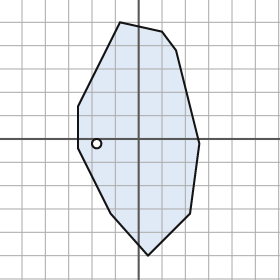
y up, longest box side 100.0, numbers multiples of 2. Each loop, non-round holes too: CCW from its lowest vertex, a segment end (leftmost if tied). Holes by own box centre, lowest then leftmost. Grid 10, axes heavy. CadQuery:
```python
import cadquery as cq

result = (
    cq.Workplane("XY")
    .moveTo(4.0, -50.0)
    .lineTo(22.0, -32.0)
    .lineTo(26.0, -2.0)
    .lineTo(16.0, 38.0)
    .lineTo(10.0, 46.0)
    .lineTo(-8.0, 50.0)
    .lineTo(-26.0, 14.0)
    .lineTo(-26.0, -4.0)
    .lineTo(-12.0, -32.0)
    .close()
    .moveTo(-18.0, -2.0)
    .circle(2.0)
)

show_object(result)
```